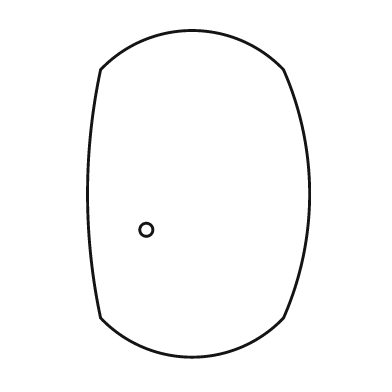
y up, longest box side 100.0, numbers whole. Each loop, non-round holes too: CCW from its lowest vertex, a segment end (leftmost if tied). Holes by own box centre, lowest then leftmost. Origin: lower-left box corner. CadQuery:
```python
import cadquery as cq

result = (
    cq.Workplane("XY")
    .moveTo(4.0, 12.0)
    .threePointArc((32.0, 0.0), (60.0, 12.0))
    .threePointArc((68.0, 50.0), (60.0, 88.0))
    .threePointArc((32.0, 100.0), (4.0, 88.0))
    .threePointArc((0.0, 50.0), (4.0, 12.0))
    .close()
    .moveTo(18.0, 39.0)
    .circle(2.0)
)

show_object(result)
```